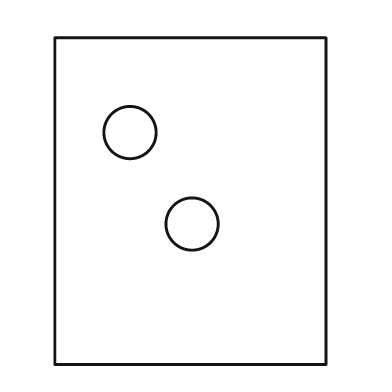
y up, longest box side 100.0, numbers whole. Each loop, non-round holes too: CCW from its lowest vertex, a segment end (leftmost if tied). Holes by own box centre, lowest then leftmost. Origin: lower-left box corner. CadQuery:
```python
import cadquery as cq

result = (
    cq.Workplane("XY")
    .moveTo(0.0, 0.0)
    .lineTo(83.0, 0.0)
    .lineTo(83.0, 100.0)
    .lineTo(0.0, 100.0)
    .close()
    .moveTo(42.0, 43.0)
    .circle(8.0)
    .moveTo(23.0, 71.0)
    .circle(8.0)
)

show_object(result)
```